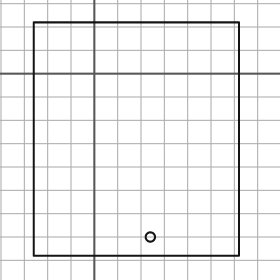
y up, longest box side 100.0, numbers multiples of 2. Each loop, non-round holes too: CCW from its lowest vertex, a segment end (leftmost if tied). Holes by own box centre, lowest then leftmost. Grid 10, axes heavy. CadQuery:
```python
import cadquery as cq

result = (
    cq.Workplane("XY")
    .moveTo(-26.0, -78.0)
    .lineTo(62.0, -78.0)
    .lineTo(62.0, 22.0)
    .lineTo(-26.0, 22.0)
    .close()
    .moveTo(24.0, -70.0)
    .circle(2.0)
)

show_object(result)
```